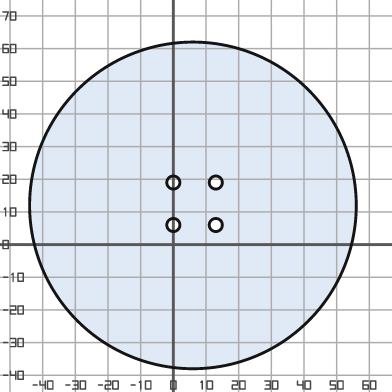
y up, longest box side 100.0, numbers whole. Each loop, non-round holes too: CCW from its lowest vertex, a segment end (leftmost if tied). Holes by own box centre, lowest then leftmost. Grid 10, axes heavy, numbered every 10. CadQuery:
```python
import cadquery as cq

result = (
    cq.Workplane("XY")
    .moveTo(6.0, 12.0)
    .circle(50.0)
    .moveTo(0.0, 6.0)
    .circle(2.0)
    .moveTo(13.0, 6.0)
    .circle(2.0)
    .moveTo(0.0, 19.0)
    .circle(2.0)
    .moveTo(13.0, 19.0)
    .circle(2.0)
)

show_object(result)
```